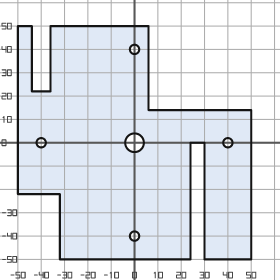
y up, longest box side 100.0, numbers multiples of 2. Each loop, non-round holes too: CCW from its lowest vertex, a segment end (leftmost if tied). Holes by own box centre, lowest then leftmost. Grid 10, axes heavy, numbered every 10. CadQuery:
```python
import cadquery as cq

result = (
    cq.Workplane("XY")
    .moveTo(-32.0, -50.0)
    .lineTo(24.0, -50.0)
    .lineTo(24.0, 0.0)
    .lineTo(30.0, 0.0)
    .lineTo(30.0, -50.0)
    .lineTo(50.0, -50.0)
    .lineTo(50.0, 14.0)
    .lineTo(6.0, 14.0)
    .lineTo(6.0, 50.0)
    .lineTo(-36.0, 50.0)
    .lineTo(-36.0, 22.0)
    .lineTo(-44.0, 22.0)
    .lineTo(-44.0, 50.0)
    .lineTo(-50.0, 50.0)
    .lineTo(-50.0, -22.0)
    .lineTo(-32.0, -22.0)
    .close()
    .moveTo(0.0, -40.0)
    .circle(2.0)
    .moveTo(-40.0, 0.0)
    .circle(2.0)
    .moveTo(0.0, 0.0)
    .circle(4.0)
    .moveTo(40.0, 0.0)
    .circle(2.0)
    .moveTo(0.0, 40.0)
    .circle(2.0)
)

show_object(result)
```